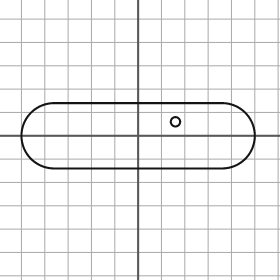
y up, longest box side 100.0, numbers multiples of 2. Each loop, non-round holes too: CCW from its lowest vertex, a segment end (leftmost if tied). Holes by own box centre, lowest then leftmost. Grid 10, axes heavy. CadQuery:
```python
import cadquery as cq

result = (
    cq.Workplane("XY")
    .moveTo(-36.0, -14.0)
    .lineTo(36.0, -14.0)
    .threePointArc((50.0, 0.0), (36.0, 14.0))
    .lineTo(-36.0, 14.0)
    .threePointArc((-50.0, 0.0), (-36.0, -14.0))
    .close()
    .moveTo(16.0, 6.0)
    .circle(2.0)
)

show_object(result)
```